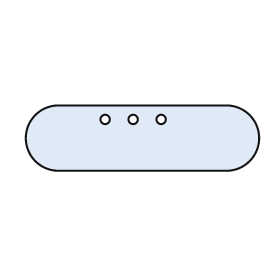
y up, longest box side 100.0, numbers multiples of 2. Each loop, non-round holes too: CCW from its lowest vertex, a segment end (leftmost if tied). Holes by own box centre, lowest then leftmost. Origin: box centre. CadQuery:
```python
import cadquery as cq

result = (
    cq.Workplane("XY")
    .moveTo(-36.0, -14.0)
    .lineTo(36.0, -14.0)
    .threePointArc((50.0, 0.0), (36.0, 14.0))
    .lineTo(-36.0, 14.0)
    .threePointArc((-50.0, 0.0), (-36.0, -14.0))
    .close()
    .moveTo(-16.0, 8.0)
    .circle(2.0)
    .moveTo(-4.0, 8.0)
    .circle(2.0)
    .moveTo(8.0, 8.0)
    .circle(2.0)
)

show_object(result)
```